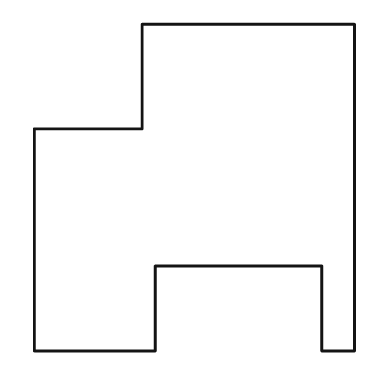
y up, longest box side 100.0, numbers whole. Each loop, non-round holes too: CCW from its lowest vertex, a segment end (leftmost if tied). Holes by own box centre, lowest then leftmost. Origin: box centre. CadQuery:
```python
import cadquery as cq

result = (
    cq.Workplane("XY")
    .moveTo(-49.0, -50.0)
    .lineTo(-12.0, -50.0)
    .lineTo(-12.0, -24.0)
    .lineTo(39.0, -24.0)
    .lineTo(39.0, -50.0)
    .lineTo(49.0, -50.0)
    .lineTo(49.0, 50.0)
    .lineTo(-16.0, 50.0)
    .lineTo(-16.0, 18.0)
    .lineTo(-49.0, 18.0)
    .close()
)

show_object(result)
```